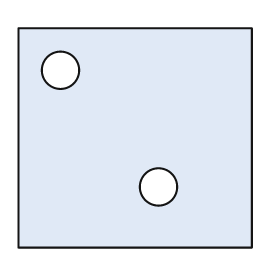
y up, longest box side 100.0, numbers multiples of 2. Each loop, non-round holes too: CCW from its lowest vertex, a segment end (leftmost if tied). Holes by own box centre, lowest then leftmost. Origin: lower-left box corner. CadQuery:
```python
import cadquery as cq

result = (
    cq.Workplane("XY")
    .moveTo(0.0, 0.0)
    .lineTo(100.0, 0.0)
    .lineTo(100.0, 94.0)
    .lineTo(0.0, 94.0)
    .close()
    .moveTo(60.0, 26.0)
    .circle(8.0)
    .moveTo(18.0, 76.0)
    .circle(8.0)
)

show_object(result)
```